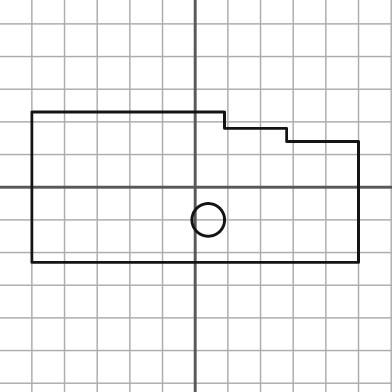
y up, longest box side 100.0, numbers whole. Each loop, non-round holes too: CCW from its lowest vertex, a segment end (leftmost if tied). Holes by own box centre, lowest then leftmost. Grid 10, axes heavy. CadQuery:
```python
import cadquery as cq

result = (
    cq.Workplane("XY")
    .moveTo(-50.0, -23.0)
    .lineTo(50.0, -23.0)
    .lineTo(50.0, 14.0)
    .lineTo(28.0, 14.0)
    .lineTo(28.0, 18.0)
    .lineTo(9.0, 18.0)
    .lineTo(9.0, 23.0)
    .lineTo(-50.0, 23.0)
    .close()
    .moveTo(4.0, -10.0)
    .circle(5.0)
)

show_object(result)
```